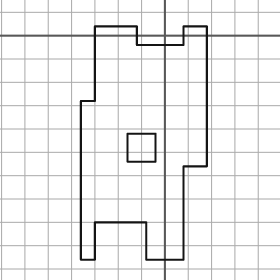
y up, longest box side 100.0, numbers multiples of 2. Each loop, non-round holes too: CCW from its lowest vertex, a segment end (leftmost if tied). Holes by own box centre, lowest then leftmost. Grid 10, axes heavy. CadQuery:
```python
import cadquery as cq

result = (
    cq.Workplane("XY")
    .moveTo(-36.0, -96.0)
    .lineTo(-30.0, -96.0)
    .lineTo(-30.0, -80.0)
    .lineTo(-8.0, -80.0)
    .lineTo(-8.0, -96.0)
    .lineTo(8.0, -96.0)
    .lineTo(8.0, -56.0)
    .lineTo(18.0, -56.0)
    .lineTo(18.0, 4.0)
    .lineTo(8.0, 4.0)
    .lineTo(8.0, -4.0)
    .lineTo(-12.0, -4.0)
    .lineTo(-12.0, 4.0)
    .lineTo(-30.0, 4.0)
    .lineTo(-30.0, -28.0)
    .lineTo(-36.0, -28.0)
    .close()
    .moveTo(-16.0, -54.0)
    .lineTo(-4.0, -54.0)
    .lineTo(-4.0, -42.0)
    .lineTo(-16.0, -42.0)
    .close()
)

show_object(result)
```